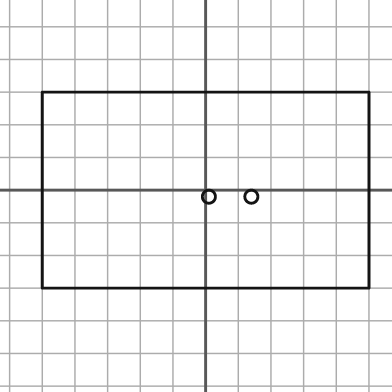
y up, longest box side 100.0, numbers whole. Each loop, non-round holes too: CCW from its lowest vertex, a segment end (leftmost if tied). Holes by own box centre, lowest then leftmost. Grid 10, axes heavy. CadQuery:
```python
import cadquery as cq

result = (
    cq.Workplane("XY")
    .moveTo(-50.0, -30.0)
    .lineTo(50.0, -30.0)
    .lineTo(50.0, 30.0)
    .lineTo(-50.0, 30.0)
    .close()
    .moveTo(1.0, -2.0)
    .circle(2.0)
    .moveTo(14.0, -2.0)
    .circle(2.0)
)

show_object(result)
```